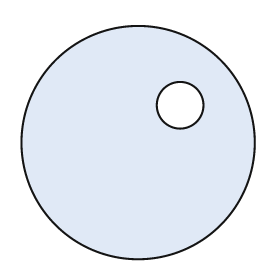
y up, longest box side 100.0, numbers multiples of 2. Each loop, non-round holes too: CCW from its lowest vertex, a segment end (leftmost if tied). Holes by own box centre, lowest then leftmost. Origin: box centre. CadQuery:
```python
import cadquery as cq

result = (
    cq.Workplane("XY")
    .moveTo(0.0, 0.0)
    .circle(50.0)
    .moveTo(18.0, 16.0)
    .circle(10.0)
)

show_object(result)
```